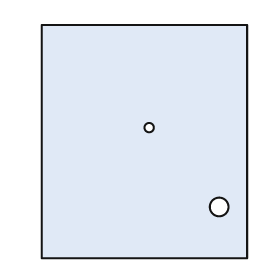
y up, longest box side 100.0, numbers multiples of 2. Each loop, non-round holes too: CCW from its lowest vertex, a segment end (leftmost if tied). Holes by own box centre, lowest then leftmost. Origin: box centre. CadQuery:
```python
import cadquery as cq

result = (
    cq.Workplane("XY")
    .moveTo(-44.0, -50.0)
    .lineTo(44.0, -50.0)
    .lineTo(44.0, 50.0)
    .lineTo(-44.0, 50.0)
    .close()
    .moveTo(32.0, -28.0)
    .circle(4.0)
    .moveTo(2.0, 6.0)
    .circle(2.0)
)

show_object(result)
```